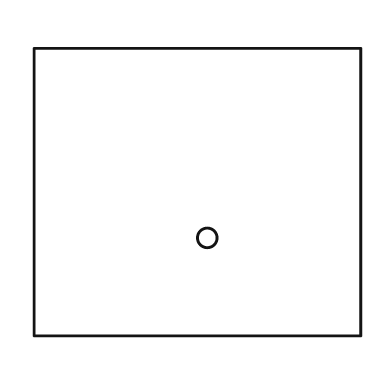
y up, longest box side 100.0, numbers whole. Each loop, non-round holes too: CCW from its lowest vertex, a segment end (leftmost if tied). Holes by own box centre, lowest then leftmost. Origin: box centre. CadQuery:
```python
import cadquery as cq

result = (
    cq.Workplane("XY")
    .moveTo(-50.0, -44.0)
    .lineTo(50.0, -44.0)
    .lineTo(50.0, 44.0)
    .lineTo(-50.0, 44.0)
    .close()
    .moveTo(3.0, -14.0)
    .circle(3.0)
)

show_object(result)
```